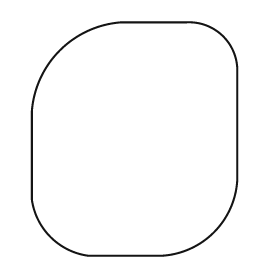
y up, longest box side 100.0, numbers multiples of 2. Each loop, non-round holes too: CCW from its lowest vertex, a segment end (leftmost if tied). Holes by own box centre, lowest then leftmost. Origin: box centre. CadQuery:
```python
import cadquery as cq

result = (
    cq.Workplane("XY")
    .moveTo(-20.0, -50.0)
    .lineTo(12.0, -50.0)
    .threePointArc((34.0, -40.0), (44.0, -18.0))
    .lineTo(44.0, 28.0)
    .threePointArc((38.0, 44.0), (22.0, 50.0))
    .lineTo(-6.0, 50.0)
    .threePointArc((-32.0, 38.0), (-44.0, 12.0))
    .lineTo(-44.0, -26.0)
    .threePointArc((-36.0, -42.0), (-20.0, -50.0))
    .close()
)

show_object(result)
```